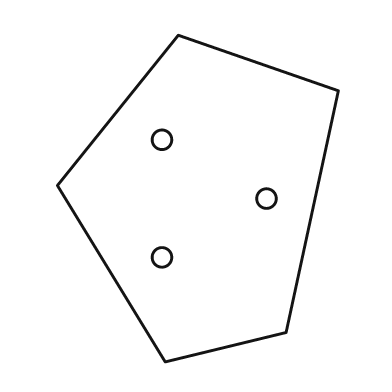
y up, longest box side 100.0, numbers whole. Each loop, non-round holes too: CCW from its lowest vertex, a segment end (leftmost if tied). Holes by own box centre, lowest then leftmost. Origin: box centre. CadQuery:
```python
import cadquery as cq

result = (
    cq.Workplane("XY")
    .moveTo(-10.0, -50.0)
    .lineTo(27.0, -41.0)
    .lineTo(43.0, 33.0)
    .lineTo(-6.0, 50.0)
    .lineTo(-43.0, 4.0)
    .close()
    .moveTo(-11.0, -18.0)
    .circle(3.0)
    .moveTo(21.0, 0.0)
    .circle(3.0)
    .moveTo(-11.0, 18.0)
    .circle(3.0)
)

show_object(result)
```